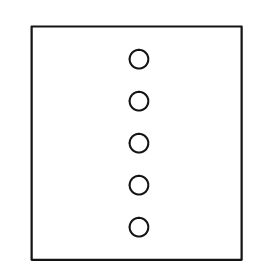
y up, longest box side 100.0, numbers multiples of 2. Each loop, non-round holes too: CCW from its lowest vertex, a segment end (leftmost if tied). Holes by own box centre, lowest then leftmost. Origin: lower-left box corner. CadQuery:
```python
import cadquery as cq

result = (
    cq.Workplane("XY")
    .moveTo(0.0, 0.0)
    .lineTo(90.0, 0.0)
    .lineTo(90.0, 100.0)
    .lineTo(0.0, 100.0)
    .close()
    .moveTo(46.0, 14.0)
    .circle(4.0)
    .moveTo(46.0, 32.0)
    .circle(4.0)
    .moveTo(46.0, 50.0)
    .circle(4.0)
    .moveTo(46.0, 68.0)
    .circle(4.0)
    .moveTo(46.0, 86.0)
    .circle(4.0)
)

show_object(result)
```